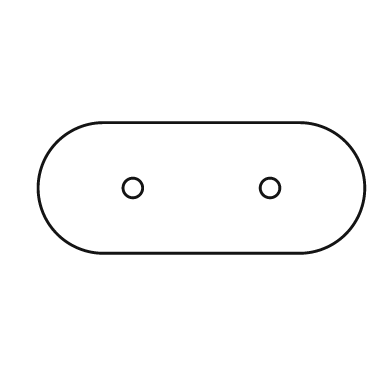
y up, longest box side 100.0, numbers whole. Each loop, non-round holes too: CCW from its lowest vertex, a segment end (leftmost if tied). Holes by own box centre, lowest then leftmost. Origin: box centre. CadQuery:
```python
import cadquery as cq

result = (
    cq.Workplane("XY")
    .moveTo(-30.0, -20.0)
    .lineTo(30.0, -20.0)
    .threePointArc((50.0, 0.0), (30.0, 20.0))
    .lineTo(-30.0, 20.0)
    .threePointArc((-50.0, 0.0), (-30.0, -20.0))
    .close()
    .moveTo(-21.0, 0.0)
    .circle(3.0)
    .moveTo(21.0, 0.0)
    .circle(3.0)
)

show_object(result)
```